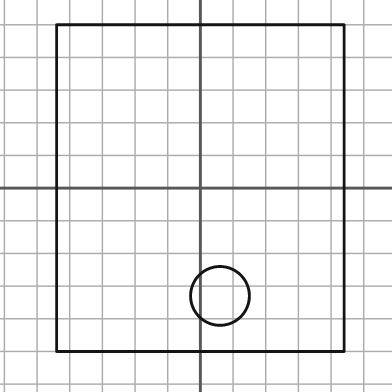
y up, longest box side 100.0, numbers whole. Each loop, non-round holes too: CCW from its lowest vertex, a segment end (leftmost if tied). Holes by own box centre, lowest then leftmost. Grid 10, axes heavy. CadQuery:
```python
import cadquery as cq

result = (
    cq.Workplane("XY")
    .moveTo(-44.0, -50.0)
    .lineTo(44.0, -50.0)
    .lineTo(44.0, 50.0)
    .lineTo(-44.0, 50.0)
    .close()
    .moveTo(6.0, -33.0)
    .circle(9.0)
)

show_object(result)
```